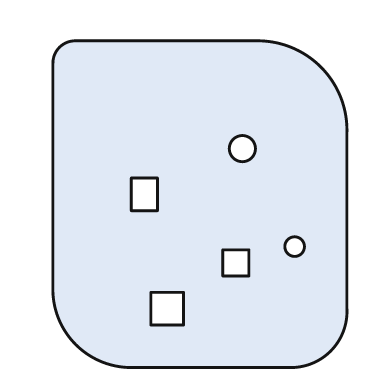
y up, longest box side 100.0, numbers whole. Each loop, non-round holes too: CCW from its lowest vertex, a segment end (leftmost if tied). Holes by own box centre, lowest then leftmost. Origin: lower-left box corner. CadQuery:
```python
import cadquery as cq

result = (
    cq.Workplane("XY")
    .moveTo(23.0, 0.0)
    .lineTo(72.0, 0.0)
    .threePointArc((85.0, 5.0), (90.0, 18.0))
    .lineTo(90.0, 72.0)
    .threePointArc((82.0, 92.0), (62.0, 100.0))
    .lineTo(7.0, 100.0)
    .threePointArc((2.0, 98.0), (0.0, 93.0))
    .lineTo(0.0, 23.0)
    .threePointArc((7.0, 7.0), (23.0, 0.0))
    .close()
    .moveTo(30.0, 13.0)
    .lineTo(40.0, 13.0)
    .lineTo(40.0, 23.0)
    .lineTo(30.0, 23.0)
    .close()
    .moveTo(52.0, 28.0)
    .lineTo(60.0, 28.0)
    .lineTo(60.0, 36.0)
    .lineTo(52.0, 36.0)
    .close()
    .moveTo(74.0, 37.0)
    .circle(3.0)
    .moveTo(24.0, 48.0)
    .lineTo(32.0, 48.0)
    .lineTo(32.0, 58.0)
    .lineTo(24.0, 58.0)
    .close()
    .moveTo(58.0, 67.0)
    .circle(4.0)
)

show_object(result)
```